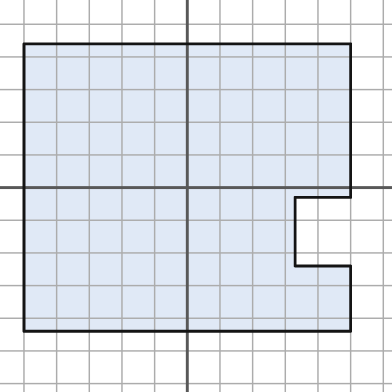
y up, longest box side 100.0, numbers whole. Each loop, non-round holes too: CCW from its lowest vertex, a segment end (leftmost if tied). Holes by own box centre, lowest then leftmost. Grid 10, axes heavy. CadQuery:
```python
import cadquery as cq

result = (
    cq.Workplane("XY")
    .moveTo(-50.0, -44.0)
    .lineTo(50.0, -44.0)
    .lineTo(50.0, -24.0)
    .lineTo(33.0, -24.0)
    .lineTo(33.0, -3.0)
    .lineTo(50.0, -3.0)
    .lineTo(50.0, 44.0)
    .lineTo(-50.0, 44.0)
    .close()
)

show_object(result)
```